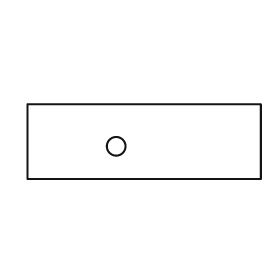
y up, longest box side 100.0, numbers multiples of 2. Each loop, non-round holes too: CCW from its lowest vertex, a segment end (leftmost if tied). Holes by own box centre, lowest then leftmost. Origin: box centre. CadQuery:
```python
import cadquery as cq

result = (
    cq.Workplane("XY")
    .moveTo(-50.0, -16.0)
    .lineTo(50.0, -16.0)
    .lineTo(50.0, 16.0)
    .lineTo(-50.0, 16.0)
    .close()
    .moveTo(-12.0, -2.0)
    .circle(4.0)
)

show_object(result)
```